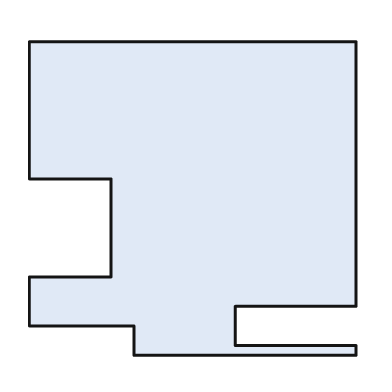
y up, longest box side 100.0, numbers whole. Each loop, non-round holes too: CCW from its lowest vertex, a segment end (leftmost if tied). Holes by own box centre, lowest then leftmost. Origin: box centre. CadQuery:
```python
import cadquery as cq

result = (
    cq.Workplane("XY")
    .moveTo(-18.0, -48.0)
    .lineTo(50.0, -48.0)
    .lineTo(50.0, -45.0)
    .lineTo(13.0, -45.0)
    .lineTo(13.0, -33.0)
    .lineTo(50.0, -33.0)
    .lineTo(50.0, 48.0)
    .lineTo(-50.0, 48.0)
    .lineTo(-50.0, 6.0)
    .lineTo(-25.0, 6.0)
    .lineTo(-25.0, -24.0)
    .lineTo(-50.0, -24.0)
    .lineTo(-50.0, -39.0)
    .lineTo(-18.0, -39.0)
    .close()
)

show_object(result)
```